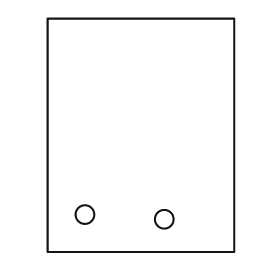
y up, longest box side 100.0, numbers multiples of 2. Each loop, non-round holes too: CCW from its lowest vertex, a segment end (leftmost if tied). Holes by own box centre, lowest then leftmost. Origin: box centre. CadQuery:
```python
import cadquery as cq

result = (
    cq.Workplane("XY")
    .moveTo(-40.0, -50.0)
    .lineTo(40.0, -50.0)
    .lineTo(40.0, 50.0)
    .lineTo(-40.0, 50.0)
    .close()
    .moveTo(10.0, -36.0)
    .circle(4.0)
    .moveTo(-24.0, -34.0)
    .circle(4.0)
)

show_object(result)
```